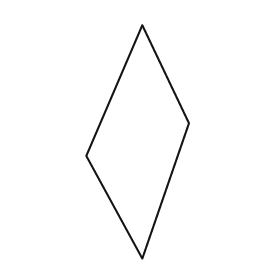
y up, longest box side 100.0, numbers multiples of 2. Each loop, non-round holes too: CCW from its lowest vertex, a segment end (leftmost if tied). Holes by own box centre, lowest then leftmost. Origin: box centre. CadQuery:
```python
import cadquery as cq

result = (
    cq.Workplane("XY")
    .moveTo(2.0, -50.0)
    .lineTo(22.0, 8.0)
    .lineTo(2.0, 50.0)
    .lineTo(-22.0, -6.0)
    .close()
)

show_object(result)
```